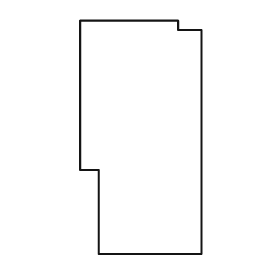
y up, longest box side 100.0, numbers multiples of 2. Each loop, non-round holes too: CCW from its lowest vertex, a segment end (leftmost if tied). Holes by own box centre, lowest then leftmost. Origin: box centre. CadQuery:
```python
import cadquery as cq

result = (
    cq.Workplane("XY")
    .moveTo(-18.0, -50.0)
    .lineTo(26.0, -50.0)
    .lineTo(26.0, 46.0)
    .lineTo(16.0, 46.0)
    .lineTo(16.0, 50.0)
    .lineTo(-26.0, 50.0)
    .lineTo(-26.0, -14.0)
    .lineTo(-18.0, -14.0)
    .close()
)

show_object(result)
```